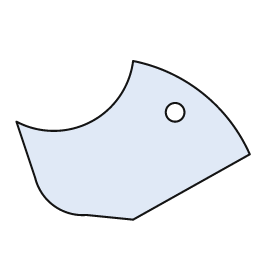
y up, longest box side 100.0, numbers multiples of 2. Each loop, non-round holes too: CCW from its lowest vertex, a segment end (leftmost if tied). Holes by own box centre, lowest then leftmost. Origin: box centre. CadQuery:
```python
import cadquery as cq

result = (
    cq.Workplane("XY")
    .moveTo(0.0, -34.0)
    .lineTo(50.0, -6.0)
    .threePointArc((30.0, 20.0), (0.0, 34.0))
    .threePointArc((-18.0, 8.0), (-50.0, 8.0))
    .lineTo(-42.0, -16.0)
    .threePointArc((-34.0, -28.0), (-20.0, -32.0))
    .close()
    .moveTo(18.0, 12.0)
    .circle(4.0)
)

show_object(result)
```